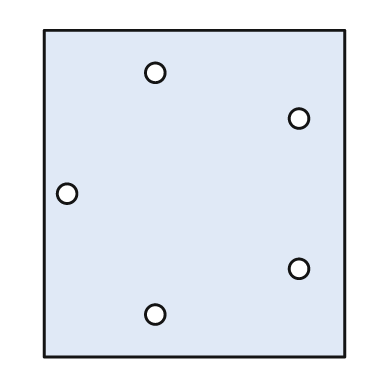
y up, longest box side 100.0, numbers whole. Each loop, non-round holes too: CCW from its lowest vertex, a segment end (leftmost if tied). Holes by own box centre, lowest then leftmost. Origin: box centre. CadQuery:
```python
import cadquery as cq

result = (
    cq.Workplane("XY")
    .moveTo(-46.0, -50.0)
    .lineTo(46.0, -50.0)
    .lineTo(46.0, 50.0)
    .lineTo(-46.0, 50.0)
    .close()
    .moveTo(-12.0, -37.0)
    .circle(3.0)
    .moveTo(32.0, -23.0)
    .circle(3.0)
    .moveTo(-39.0, 0.0)
    .circle(3.0)
    .moveTo(32.0, 23.0)
    .circle(3.0)
    .moveTo(-12.0, 37.0)
    .circle(3.0)
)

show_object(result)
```